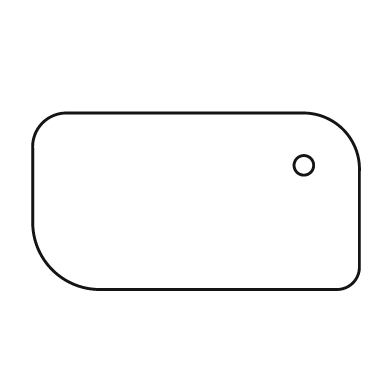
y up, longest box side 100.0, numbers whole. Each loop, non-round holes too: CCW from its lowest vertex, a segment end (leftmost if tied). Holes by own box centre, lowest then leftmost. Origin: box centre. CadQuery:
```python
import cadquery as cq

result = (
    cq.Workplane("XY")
    .moveTo(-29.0, -27.0)
    .lineTo(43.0, -27.0)
    .threePointArc((48.0, -25.0), (50.0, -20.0))
    .lineTo(50.0, 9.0)
    .threePointArc((45.0, 22.0), (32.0, 27.0))
    .lineTo(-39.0, 27.0)
    .threePointArc((-47.0, 24.0), (-50.0, 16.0))
    .lineTo(-50.0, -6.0)
    .threePointArc((-44.0, -21.0), (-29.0, -27.0))
    .close()
    .moveTo(33.0, 11.0)
    .circle(3.0)
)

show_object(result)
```